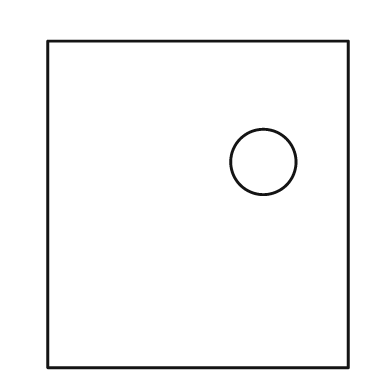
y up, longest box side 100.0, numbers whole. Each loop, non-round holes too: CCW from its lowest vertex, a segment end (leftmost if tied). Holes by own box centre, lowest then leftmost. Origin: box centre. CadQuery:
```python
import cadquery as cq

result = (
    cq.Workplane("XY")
    .moveTo(-46.0, -50.0)
    .lineTo(46.0, -50.0)
    .lineTo(46.0, 50.0)
    .lineTo(-46.0, 50.0)
    .close()
    .moveTo(20.0, 13.0)
    .circle(10.0)
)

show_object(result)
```